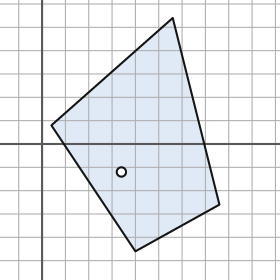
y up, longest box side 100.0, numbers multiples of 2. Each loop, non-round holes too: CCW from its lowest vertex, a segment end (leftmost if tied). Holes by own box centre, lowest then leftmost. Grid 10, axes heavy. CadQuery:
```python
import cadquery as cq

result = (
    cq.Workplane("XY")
    .moveTo(40.0, -46.0)
    .lineTo(76.0, -26.0)
    .lineTo(56.0, 54.0)
    .lineTo(4.0, 8.0)
    .close()
    .moveTo(34.0, -12.0)
    .circle(2.0)
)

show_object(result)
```